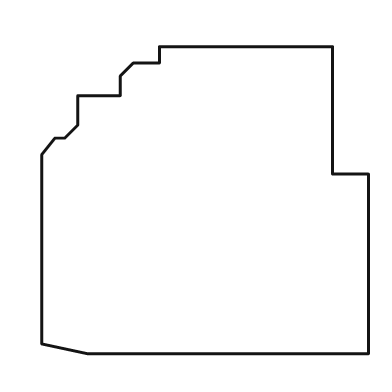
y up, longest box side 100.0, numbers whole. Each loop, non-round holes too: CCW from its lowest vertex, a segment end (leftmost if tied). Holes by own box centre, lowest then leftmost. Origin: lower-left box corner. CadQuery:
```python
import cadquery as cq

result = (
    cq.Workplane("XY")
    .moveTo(14.0, 0.0)
    .lineTo(100.0, 0.0)
    .lineTo(100.0, 55.0)
    .lineTo(89.0, 55.0)
    .lineTo(89.0, 94.0)
    .lineTo(36.0, 94.0)
    .lineTo(36.0, 89.0)
    .lineTo(28.0, 89.0)
    .lineTo(24.0, 85.0)
    .lineTo(24.0, 79.0)
    .lineTo(11.0, 79.0)
    .lineTo(11.0, 70.0)
    .lineTo(7.0, 66.0)
    .lineTo(4.0, 66.0)
    .lineTo(0.0, 61.0)
    .lineTo(0.0, 3.0)
    .close()
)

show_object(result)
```